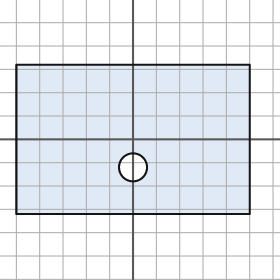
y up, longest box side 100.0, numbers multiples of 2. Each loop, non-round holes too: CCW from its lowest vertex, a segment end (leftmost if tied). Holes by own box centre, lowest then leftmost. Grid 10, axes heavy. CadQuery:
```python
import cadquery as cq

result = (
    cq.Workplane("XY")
    .moveTo(-50.0, -32.0)
    .lineTo(50.0, -32.0)
    .lineTo(50.0, 32.0)
    .lineTo(-50.0, 32.0)
    .close()
    .moveTo(0.0, -12.0)
    .circle(6.0)
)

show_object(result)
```